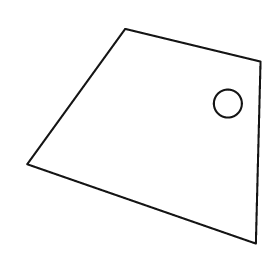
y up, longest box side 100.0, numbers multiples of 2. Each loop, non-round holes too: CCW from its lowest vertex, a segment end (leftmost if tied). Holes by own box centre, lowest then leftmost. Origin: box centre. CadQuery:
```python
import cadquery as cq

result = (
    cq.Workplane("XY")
    .moveTo(48.0, -46.0)
    .lineTo(50.0, 32.0)
    .lineTo(-8.0, 46.0)
    .lineTo(-50.0, -12.0)
    .close()
    .moveTo(36.0, 14.0)
    .circle(6.0)
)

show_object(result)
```